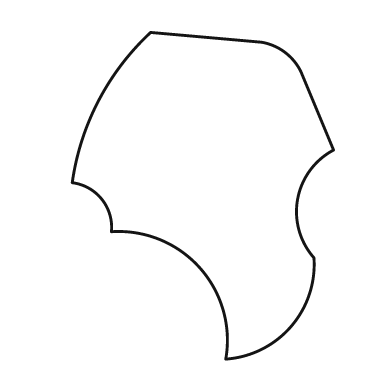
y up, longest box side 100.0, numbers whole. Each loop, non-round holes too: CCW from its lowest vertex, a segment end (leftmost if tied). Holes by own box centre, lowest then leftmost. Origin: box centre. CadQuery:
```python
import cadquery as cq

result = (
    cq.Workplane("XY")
    .moveTo(7.0, -50.0)
    .threePointArc((27.0, -40.0), (34.0, -19.0))
    .threePointArc((29.0, -1.0), (40.0, 14.0))
    .lineTo(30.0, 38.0)
    .threePointArc((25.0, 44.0), (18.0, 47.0))
    .lineTo(-16.0, 50.0)
    .threePointArc((-32.0, 29.0), (-40.0, 4.0))
    .threePointArc((-31.0, -1.0), (-28.0, -11.0))
    .threePointArc((-1.0, -22.0), (7.0, -50.0))
    .close()
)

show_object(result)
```